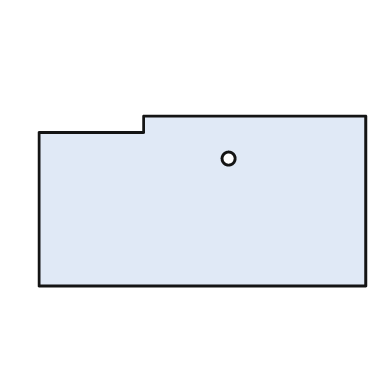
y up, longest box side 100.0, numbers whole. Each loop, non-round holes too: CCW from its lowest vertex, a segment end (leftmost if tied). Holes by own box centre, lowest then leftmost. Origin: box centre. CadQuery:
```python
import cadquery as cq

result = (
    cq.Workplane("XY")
    .moveTo(-50.0, -26.0)
    .lineTo(50.0, -26.0)
    .lineTo(50.0, 26.0)
    .lineTo(-18.0, 26.0)
    .lineTo(-18.0, 21.0)
    .lineTo(-50.0, 21.0)
    .close()
    .moveTo(8.0, 13.0)
    .circle(2.0)
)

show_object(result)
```